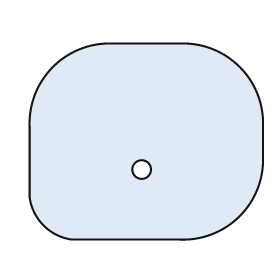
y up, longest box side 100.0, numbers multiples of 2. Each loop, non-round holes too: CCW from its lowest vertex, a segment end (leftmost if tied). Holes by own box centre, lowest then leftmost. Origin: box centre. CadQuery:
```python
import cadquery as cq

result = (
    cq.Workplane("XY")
    .moveTo(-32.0, -42.0)
    .lineTo(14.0, -42.0)
    .threePointArc((40.0, -32.0), (50.0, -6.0))
    .lineTo(50.0, 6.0)
    .threePointArc((40.0, 32.0), (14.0, 42.0))
    .lineTo(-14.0, 42.0)
    .threePointArc((-40.0, 32.0), (-50.0, 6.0))
    .lineTo(-50.0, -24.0)
    .threePointArc((-44.0, -36.0), (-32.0, -42.0))
    .close()
    .moveTo(-2.0, -12.0)
    .circle(4.0)
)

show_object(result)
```